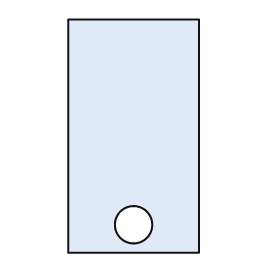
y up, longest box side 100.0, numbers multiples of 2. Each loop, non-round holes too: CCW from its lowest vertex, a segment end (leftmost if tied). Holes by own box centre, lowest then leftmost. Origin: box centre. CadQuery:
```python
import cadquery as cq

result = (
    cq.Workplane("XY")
    .moveTo(-28.0, -50.0)
    .lineTo(28.0, -50.0)
    .lineTo(28.0, 50.0)
    .lineTo(-28.0, 50.0)
    .close()
    .moveTo(0.0, -38.0)
    .circle(8.0)
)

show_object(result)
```